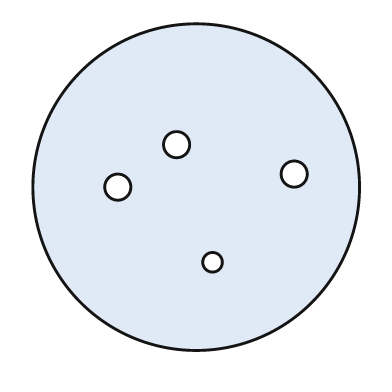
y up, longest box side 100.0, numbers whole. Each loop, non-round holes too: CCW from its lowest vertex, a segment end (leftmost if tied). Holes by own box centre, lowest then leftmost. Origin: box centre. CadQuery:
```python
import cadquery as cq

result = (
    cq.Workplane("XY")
    .moveTo(0.0, 0.0)
    .circle(50.0)
    .moveTo(5.0, -23.0)
    .circle(3.0)
    .moveTo(-24.0, 0.0)
    .circle(4.0)
    .moveTo(30.0, 4.0)
    .circle(4.0)
    .moveTo(-6.0, 13.0)
    .circle(4.0)
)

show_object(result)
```